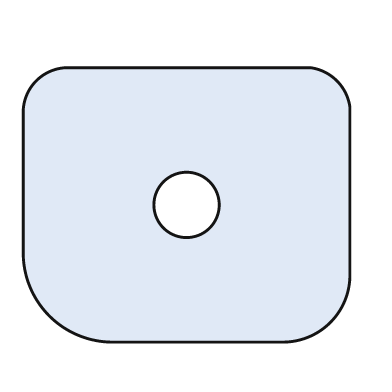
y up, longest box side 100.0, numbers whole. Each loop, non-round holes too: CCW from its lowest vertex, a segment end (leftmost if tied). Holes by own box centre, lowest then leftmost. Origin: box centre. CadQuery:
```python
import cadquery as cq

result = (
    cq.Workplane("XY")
    .moveTo(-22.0, -42.0)
    .lineTo(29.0, -42.0)
    .threePointArc((44.0, -36.0), (50.0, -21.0))
    .lineTo(50.0, 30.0)
    .threePointArc((46.0, 38.0), (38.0, 42.0))
    .lineTo(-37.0, 42.0)
    .threePointArc((-46.0, 38.0), (-50.0, 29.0))
    .lineTo(-50.0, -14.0)
    .threePointArc((-42.0, -34.0), (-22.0, -42.0))
    .close()
    .moveTo(0.0, 0.0)
    .circle(10.0)
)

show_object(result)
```